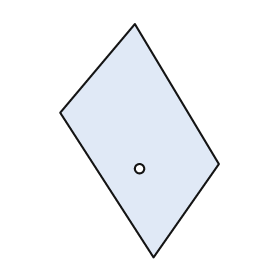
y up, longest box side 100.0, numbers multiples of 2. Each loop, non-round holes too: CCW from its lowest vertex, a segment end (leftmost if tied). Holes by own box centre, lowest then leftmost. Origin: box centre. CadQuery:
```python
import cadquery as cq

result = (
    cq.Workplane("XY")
    .moveTo(6.0, -50.0)
    .lineTo(34.0, -10.0)
    .lineTo(-2.0, 50.0)
    .lineTo(-34.0, 12.0)
    .close()
    .moveTo(0.0, -12.0)
    .circle(2.0)
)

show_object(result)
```